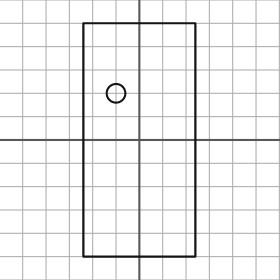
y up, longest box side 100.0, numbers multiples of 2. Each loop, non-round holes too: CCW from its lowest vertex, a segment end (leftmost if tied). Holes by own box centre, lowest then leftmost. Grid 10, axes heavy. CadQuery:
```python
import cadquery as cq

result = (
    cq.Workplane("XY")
    .moveTo(-24.0, -50.0)
    .lineTo(24.0, -50.0)
    .lineTo(24.0, 50.0)
    .lineTo(-24.0, 50.0)
    .close()
    .moveTo(-10.0, 20.0)
    .circle(4.0)
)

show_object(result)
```